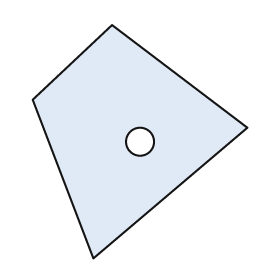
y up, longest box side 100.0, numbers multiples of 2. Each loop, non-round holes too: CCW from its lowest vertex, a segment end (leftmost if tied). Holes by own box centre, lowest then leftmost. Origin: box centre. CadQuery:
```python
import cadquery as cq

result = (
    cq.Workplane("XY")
    .moveTo(-20.0, -50.0)
    .lineTo(46.0, 6.0)
    .lineTo(-12.0, 50.0)
    .lineTo(-46.0, 18.0)
    .close()
    .moveTo(0.0, 0.0)
    .circle(6.0)
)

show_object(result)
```